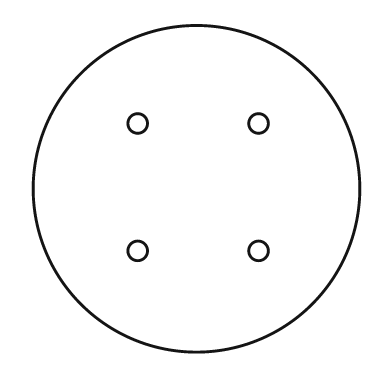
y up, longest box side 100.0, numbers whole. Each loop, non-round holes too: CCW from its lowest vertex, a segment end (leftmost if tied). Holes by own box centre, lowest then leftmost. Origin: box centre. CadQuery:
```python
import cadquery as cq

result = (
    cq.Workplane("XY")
    .moveTo(0.0, 0.0)
    .circle(50.0)
    .moveTo(-18.0, -19.0)
    .circle(3.0)
    .moveTo(19.0, -19.0)
    .circle(3.0)
    .moveTo(-18.0, 20.0)
    .circle(3.0)
    .moveTo(19.0, 20.0)
    .circle(3.0)
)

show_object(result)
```